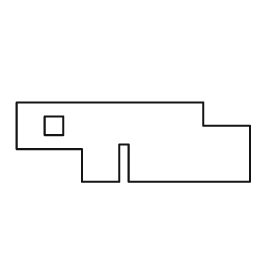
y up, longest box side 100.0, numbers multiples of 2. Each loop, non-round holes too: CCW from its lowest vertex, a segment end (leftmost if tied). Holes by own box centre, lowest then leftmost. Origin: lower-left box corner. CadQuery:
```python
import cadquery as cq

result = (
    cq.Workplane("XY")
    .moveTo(28.0, 0.0)
    .lineTo(44.0, 0.0)
    .lineTo(44.0, 16.0)
    .lineTo(48.0, 16.0)
    .lineTo(48.0, 0.0)
    .lineTo(100.0, 0.0)
    .lineTo(100.0, 24.0)
    .lineTo(80.0, 24.0)
    .lineTo(80.0, 34.0)
    .lineTo(0.0, 34.0)
    .lineTo(0.0, 14.0)
    .lineTo(28.0, 14.0)
    .close()
    .moveTo(12.0, 20.0)
    .lineTo(20.0, 20.0)
    .lineTo(20.0, 28.0)
    .lineTo(12.0, 28.0)
    .close()
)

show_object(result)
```